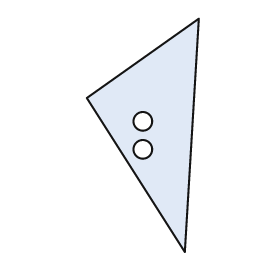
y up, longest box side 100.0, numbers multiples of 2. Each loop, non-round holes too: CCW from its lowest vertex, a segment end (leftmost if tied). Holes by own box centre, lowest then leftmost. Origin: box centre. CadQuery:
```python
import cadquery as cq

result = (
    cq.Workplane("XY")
    .moveTo(18.0, -50.0)
    .lineTo(24.0, 50.0)
    .lineTo(-24.0, 16.0)
    .close()
    .moveTo(0.0, -6.0)
    .circle(4.0)
    .moveTo(0.0, 6.0)
    .circle(4.0)
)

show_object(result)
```